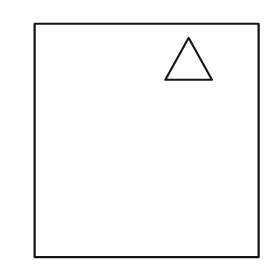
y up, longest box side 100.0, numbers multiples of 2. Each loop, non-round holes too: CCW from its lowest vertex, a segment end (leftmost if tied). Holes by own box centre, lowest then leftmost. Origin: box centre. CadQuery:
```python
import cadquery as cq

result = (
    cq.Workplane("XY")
    .moveTo(-48.0, -50.0)
    .lineTo(48.0, -50.0)
    .lineTo(48.0, 50.0)
    .lineTo(-48.0, 50.0)
    .close()
    .moveTo(8.0, 26.0)
    .lineTo(28.0, 26.0)
    .lineTo(18.0, 44.0)
    .close()
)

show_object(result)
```